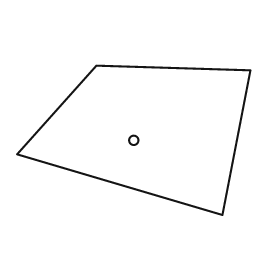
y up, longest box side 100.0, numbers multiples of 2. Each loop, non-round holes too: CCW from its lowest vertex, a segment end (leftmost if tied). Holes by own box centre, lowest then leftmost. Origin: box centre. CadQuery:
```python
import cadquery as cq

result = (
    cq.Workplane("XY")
    .moveTo(38.0, -32.0)
    .lineTo(50.0, 30.0)
    .lineTo(-16.0, 32.0)
    .lineTo(-50.0, -6.0)
    .close()
    .moveTo(0.0, 0.0)
    .circle(2.0)
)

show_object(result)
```